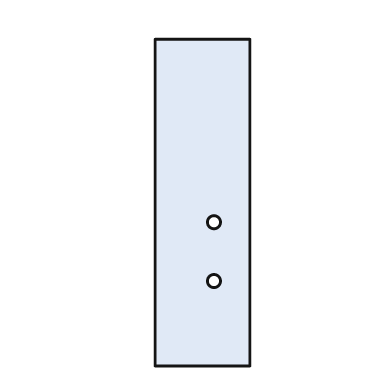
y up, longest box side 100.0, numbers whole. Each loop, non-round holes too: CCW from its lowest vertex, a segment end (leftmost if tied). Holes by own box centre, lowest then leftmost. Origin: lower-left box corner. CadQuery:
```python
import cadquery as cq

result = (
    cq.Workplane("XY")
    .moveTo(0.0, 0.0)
    .lineTo(29.0, 0.0)
    .lineTo(29.0, 100.0)
    .lineTo(0.0, 100.0)
    .close()
    .moveTo(18.0, 26.0)
    .circle(2.0)
    .moveTo(18.0, 44.0)
    .circle(2.0)
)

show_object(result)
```